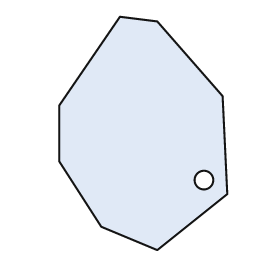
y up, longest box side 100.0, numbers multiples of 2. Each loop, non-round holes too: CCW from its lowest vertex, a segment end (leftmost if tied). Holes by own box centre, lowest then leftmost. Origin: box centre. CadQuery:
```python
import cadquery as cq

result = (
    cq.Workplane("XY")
    .moveTo(6.0, -50.0)
    .lineTo(36.0, -26.0)
    .lineTo(34.0, 16.0)
    .lineTo(6.0, 48.0)
    .lineTo(-10.0, 50.0)
    .lineTo(-36.0, 12.0)
    .lineTo(-36.0, -12.0)
    .lineTo(-18.0, -40.0)
    .close()
    .moveTo(26.0, -20.0)
    .circle(4.0)
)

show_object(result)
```